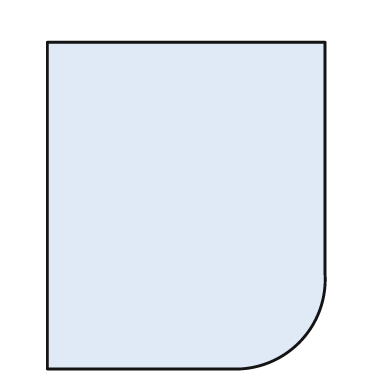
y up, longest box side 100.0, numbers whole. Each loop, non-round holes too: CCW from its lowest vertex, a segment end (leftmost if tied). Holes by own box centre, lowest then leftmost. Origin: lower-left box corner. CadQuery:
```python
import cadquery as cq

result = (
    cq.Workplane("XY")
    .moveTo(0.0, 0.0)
    .lineTo(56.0, 0.0)
    .threePointArc((77.0, 8.0), (85.0, 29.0))
    .lineTo(85.0, 100.0)
    .lineTo(0.0, 100.0)
    .close()
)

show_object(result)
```